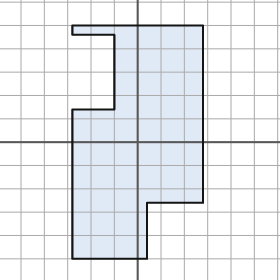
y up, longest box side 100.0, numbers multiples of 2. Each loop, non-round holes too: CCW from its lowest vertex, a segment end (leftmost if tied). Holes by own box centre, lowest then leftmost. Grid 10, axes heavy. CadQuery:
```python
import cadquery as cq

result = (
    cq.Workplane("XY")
    .moveTo(-28.0, -50.0)
    .lineTo(4.0, -50.0)
    .lineTo(4.0, -26.0)
    .lineTo(28.0, -26.0)
    .lineTo(28.0, 50.0)
    .lineTo(-28.0, 50.0)
    .lineTo(-28.0, 46.0)
    .lineTo(-10.0, 46.0)
    .lineTo(-10.0, 14.0)
    .lineTo(-28.0, 14.0)
    .close()
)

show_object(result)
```